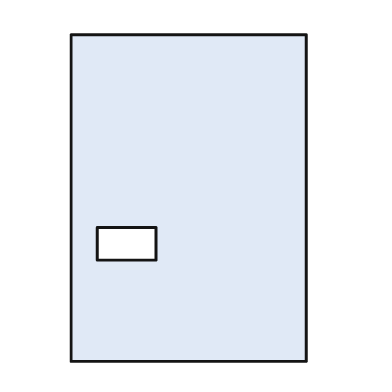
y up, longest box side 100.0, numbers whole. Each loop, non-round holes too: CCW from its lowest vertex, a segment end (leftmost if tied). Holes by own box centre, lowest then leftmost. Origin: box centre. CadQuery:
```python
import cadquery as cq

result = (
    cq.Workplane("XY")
    .moveTo(-36.0, -50.0)
    .lineTo(36.0, -50.0)
    .lineTo(36.0, 50.0)
    .lineTo(-36.0, 50.0)
    .close()
    .moveTo(-28.0, -19.0)
    .lineTo(-10.0, -19.0)
    .lineTo(-10.0, -9.0)
    .lineTo(-28.0, -9.0)
    .close()
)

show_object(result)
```